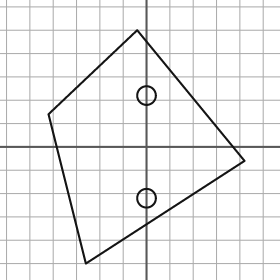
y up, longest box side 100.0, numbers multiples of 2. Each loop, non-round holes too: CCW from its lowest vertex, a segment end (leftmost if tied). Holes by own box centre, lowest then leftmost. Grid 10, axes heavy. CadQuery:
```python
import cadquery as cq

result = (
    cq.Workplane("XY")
    .moveTo(-26.0, -50.0)
    .lineTo(42.0, -6.0)
    .lineTo(-4.0, 50.0)
    .lineTo(-42.0, 14.0)
    .close()
    .moveTo(0.0, -22.0)
    .circle(4.0)
    .moveTo(0.0, 22.0)
    .circle(4.0)
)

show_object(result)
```